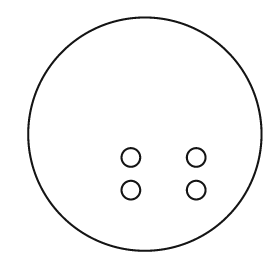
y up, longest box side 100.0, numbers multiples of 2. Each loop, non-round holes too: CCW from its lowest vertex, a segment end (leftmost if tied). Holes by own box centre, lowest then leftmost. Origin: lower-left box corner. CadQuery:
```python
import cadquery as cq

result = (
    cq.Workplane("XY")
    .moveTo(50.0, 50.0)
    .circle(50.0)
    .moveTo(44.0, 26.0)
    .circle(4.0)
    .moveTo(72.0, 26.0)
    .circle(4.0)
    .moveTo(44.0, 40.0)
    .circle(4.0)
    .moveTo(72.0, 40.0)
    .circle(4.0)
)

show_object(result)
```